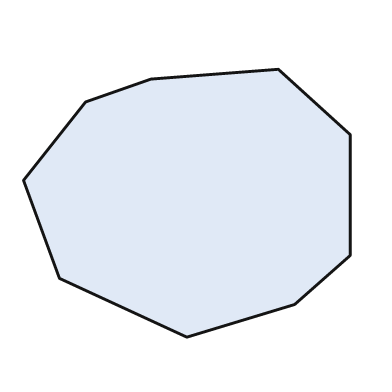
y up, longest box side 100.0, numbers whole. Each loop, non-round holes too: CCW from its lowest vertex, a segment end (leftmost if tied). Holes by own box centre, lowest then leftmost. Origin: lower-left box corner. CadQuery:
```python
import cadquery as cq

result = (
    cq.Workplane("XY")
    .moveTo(50.0, 0.0)
    .lineTo(83.0, 10.0)
    .lineTo(100.0, 25.0)
    .lineTo(100.0, 62.0)
    .lineTo(78.0, 82.0)
    .lineTo(39.0, 79.0)
    .lineTo(19.0, 72.0)
    .lineTo(0.0, 48.0)
    .lineTo(11.0, 18.0)
    .close()
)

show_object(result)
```